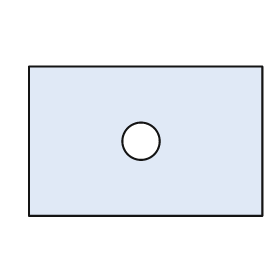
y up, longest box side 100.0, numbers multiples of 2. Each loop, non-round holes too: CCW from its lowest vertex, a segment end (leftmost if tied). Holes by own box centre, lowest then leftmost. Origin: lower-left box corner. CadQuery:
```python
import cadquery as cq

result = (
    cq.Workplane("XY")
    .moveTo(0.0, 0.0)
    .lineTo(100.0, 0.0)
    .lineTo(100.0, 64.0)
    .lineTo(0.0, 64.0)
    .close()
    .moveTo(48.0, 32.0)
    .circle(8.0)
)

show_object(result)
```